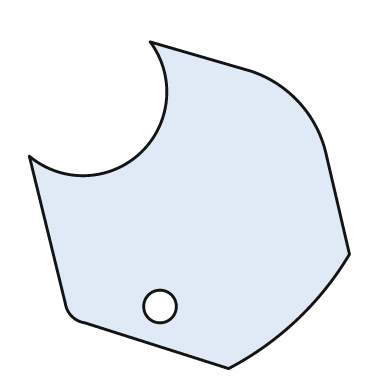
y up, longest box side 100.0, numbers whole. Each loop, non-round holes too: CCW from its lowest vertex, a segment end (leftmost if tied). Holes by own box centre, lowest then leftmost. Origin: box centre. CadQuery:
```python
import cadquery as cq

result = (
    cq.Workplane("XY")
    .moveTo(12.0, -50.0)
    .threePointArc((33.0, -35.0), (49.0, -15.0))
    .lineTo(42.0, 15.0)
    .threePointArc((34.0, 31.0), (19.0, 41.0))
    .lineTo(-12.0, 50.0)
    .threePointArc((-15.0, 16.0), (-49.0, 15.0))
    .lineTo(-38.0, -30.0)
    .threePointArc((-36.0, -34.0), (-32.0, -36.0))
    .close()
    .moveTo(-9.0, -31.0)
    .circle(5.0)
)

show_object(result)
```